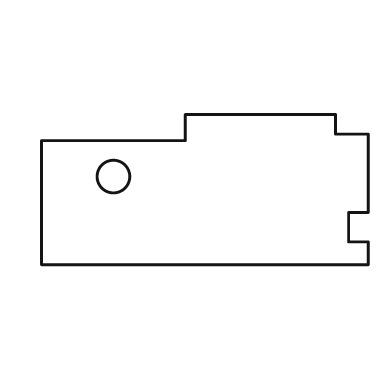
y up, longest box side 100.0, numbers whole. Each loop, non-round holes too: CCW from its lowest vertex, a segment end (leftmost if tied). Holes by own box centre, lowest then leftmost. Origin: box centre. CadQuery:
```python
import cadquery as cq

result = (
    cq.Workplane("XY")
    .moveTo(-50.0, -23.0)
    .lineTo(50.0, -23.0)
    .lineTo(50.0, -16.0)
    .lineTo(44.0, -16.0)
    .lineTo(44.0, -7.0)
    .lineTo(50.0, -7.0)
    .lineTo(50.0, 17.0)
    .lineTo(40.0, 17.0)
    .lineTo(40.0, 23.0)
    .lineTo(-6.0, 23.0)
    .lineTo(-6.0, 15.0)
    .lineTo(-50.0, 15.0)
    .close()
    .moveTo(-28.0, 4.0)
    .circle(5.0)
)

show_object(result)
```